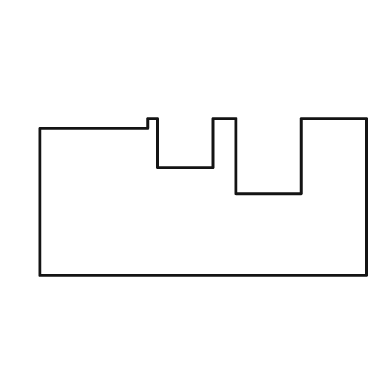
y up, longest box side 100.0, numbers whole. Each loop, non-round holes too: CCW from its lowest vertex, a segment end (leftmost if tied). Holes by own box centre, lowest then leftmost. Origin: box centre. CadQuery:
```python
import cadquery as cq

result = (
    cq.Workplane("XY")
    .moveTo(-50.0, -24.0)
    .lineTo(50.0, -24.0)
    .lineTo(50.0, 24.0)
    .lineTo(30.0, 24.0)
    .lineTo(30.0, 1.0)
    .lineTo(10.0, 1.0)
    .lineTo(10.0, 24.0)
    .lineTo(3.0, 24.0)
    .lineTo(3.0, 9.0)
    .lineTo(-14.0, 9.0)
    .lineTo(-14.0, 24.0)
    .lineTo(-17.0, 24.0)
    .lineTo(-17.0, 21.0)
    .lineTo(-50.0, 21.0)
    .close()
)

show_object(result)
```